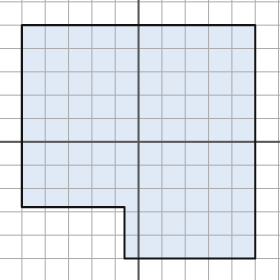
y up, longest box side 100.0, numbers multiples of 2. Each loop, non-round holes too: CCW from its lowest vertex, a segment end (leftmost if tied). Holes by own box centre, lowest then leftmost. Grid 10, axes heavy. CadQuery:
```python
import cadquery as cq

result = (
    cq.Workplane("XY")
    .moveTo(-6.0, -50.0)
    .lineTo(50.0, -50.0)
    .lineTo(50.0, 50.0)
    .lineTo(-50.0, 50.0)
    .lineTo(-50.0, -28.0)
    .lineTo(-6.0, -28.0)
    .close()
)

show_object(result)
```